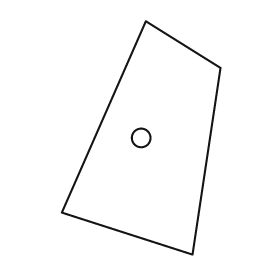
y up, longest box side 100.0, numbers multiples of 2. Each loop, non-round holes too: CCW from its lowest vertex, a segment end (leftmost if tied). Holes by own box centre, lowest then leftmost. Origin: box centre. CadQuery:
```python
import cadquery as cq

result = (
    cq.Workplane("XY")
    .moveTo(22.0, -50.0)
    .lineTo(34.0, 30.0)
    .lineTo(2.0, 50.0)
    .lineTo(-34.0, -32.0)
    .close()
    .moveTo(0.0, 0.0)
    .circle(4.0)
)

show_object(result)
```